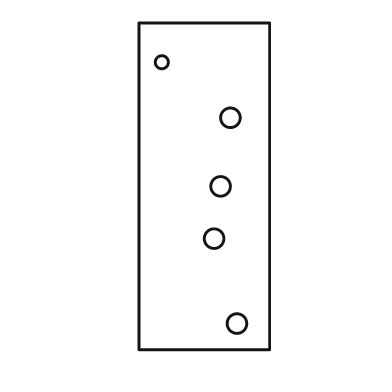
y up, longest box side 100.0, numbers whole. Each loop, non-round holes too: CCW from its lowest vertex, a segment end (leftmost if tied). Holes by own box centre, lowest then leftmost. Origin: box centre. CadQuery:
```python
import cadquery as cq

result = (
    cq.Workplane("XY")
    .moveTo(-20.0, -50.0)
    .lineTo(20.0, -50.0)
    .lineTo(20.0, 50.0)
    .lineTo(-20.0, 50.0)
    .close()
    .moveTo(10.0, -42.0)
    .circle(3.0)
    .moveTo(3.0, -16.0)
    .circle(3.0)
    .moveTo(5.0, 0.0)
    .circle(3.0)
    .moveTo(8.0, 21.0)
    .circle(3.0)
    .moveTo(-13.0, 38.0)
    .circle(2.0)
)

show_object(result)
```